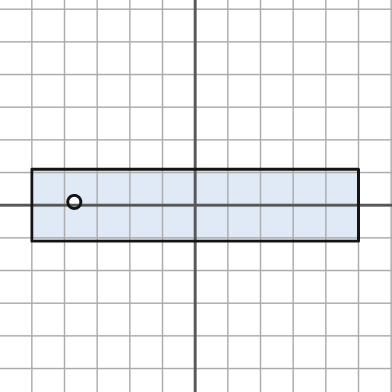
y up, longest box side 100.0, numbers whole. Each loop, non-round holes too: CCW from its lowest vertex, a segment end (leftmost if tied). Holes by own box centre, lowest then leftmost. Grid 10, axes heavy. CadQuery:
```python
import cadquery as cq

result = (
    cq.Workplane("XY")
    .moveTo(-50.0, -11.0)
    .lineTo(50.0, -11.0)
    .lineTo(50.0, 11.0)
    .lineTo(-50.0, 11.0)
    .close()
    .moveTo(-37.0, 1.0)
    .circle(2.0)
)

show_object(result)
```